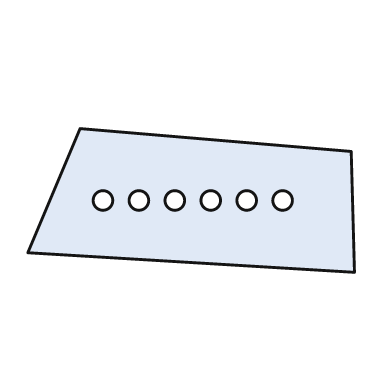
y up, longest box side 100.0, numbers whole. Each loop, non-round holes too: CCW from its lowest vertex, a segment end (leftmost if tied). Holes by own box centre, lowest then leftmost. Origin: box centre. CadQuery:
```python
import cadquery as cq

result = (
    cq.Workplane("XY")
    .moveTo(50.0, -22.0)
    .lineTo(49.0, 15.0)
    .lineTo(-34.0, 22.0)
    .lineTo(-50.0, -16.0)
    .close()
    .moveTo(-27.0, 0.0)
    .circle(3.0)
    .moveTo(-16.0, 0.0)
    .circle(3.0)
    .moveTo(-5.0, 0.0)
    .circle(3.0)
    .moveTo(6.0, 0.0)
    .circle(3.0)
    .moveTo(17.0, 0.0)
    .circle(3.0)
    .moveTo(28.0, 0.0)
    .circle(3.0)
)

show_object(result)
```